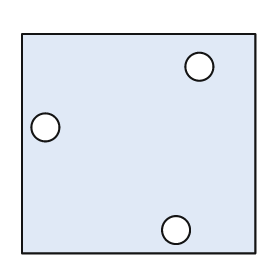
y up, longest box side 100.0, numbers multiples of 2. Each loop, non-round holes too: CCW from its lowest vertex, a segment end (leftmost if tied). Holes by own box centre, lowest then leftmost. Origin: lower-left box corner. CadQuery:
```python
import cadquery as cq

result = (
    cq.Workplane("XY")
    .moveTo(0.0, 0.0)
    .lineTo(100.0, 0.0)
    .lineTo(100.0, 94.0)
    .lineTo(0.0, 94.0)
    .close()
    .moveTo(66.0, 10.0)
    .circle(6.0)
    .moveTo(10.0, 54.0)
    .circle(6.0)
    .moveTo(76.0, 80.0)
    .circle(6.0)
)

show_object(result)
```